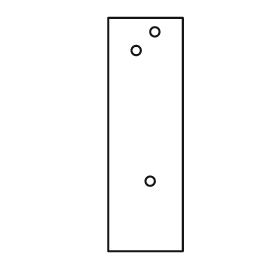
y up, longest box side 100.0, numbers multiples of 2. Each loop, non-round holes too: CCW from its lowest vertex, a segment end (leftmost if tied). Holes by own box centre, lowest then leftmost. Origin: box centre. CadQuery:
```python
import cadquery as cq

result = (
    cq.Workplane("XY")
    .moveTo(-16.0, -50.0)
    .lineTo(16.0, -50.0)
    .lineTo(16.0, 50.0)
    .lineTo(-16.0, 50.0)
    .close()
    .moveTo(2.0, -20.0)
    .circle(2.0)
    .moveTo(-4.0, 36.0)
    .circle(2.0)
    .moveTo(4.0, 44.0)
    .circle(2.0)
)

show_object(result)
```